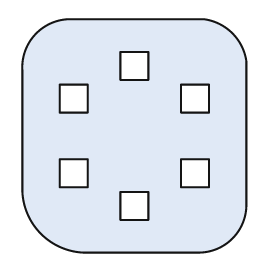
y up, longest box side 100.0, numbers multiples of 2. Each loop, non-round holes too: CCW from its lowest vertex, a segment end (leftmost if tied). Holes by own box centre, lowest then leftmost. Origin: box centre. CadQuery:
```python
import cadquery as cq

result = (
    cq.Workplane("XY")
    .moveTo(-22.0, -50.0)
    .lineTo(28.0, -50.0)
    .threePointArc((42.0, -44.0), (48.0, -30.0))
    .lineTo(48.0, 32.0)
    .threePointArc((42.0, 44.0), (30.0, 50.0))
    .lineTo(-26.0, 50.0)
    .threePointArc((-42.0, 44.0), (-48.0, 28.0))
    .lineTo(-48.0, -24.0)
    .threePointArc((-40.0, -42.0), (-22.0, -50.0))
    .close()
    .moveTo(-6.0, -36.0)
    .lineTo(6.0, -36.0)
    .lineTo(6.0, -24.0)
    .lineTo(-6.0, -24.0)
    .close()
    .moveTo(-32.0, -22.0)
    .lineTo(-20.0, -22.0)
    .lineTo(-20.0, -10.0)
    .lineTo(-32.0, -10.0)
    .close()
    .moveTo(20.0, -22.0)
    .lineTo(32.0, -22.0)
    .lineTo(32.0, -10.0)
    .lineTo(20.0, -10.0)
    .close()
    .moveTo(-32.0, 10.0)
    .lineTo(-20.0, 10.0)
    .lineTo(-20.0, 22.0)
    .lineTo(-32.0, 22.0)
    .close()
    .moveTo(20.0, 10.0)
    .lineTo(32.0, 10.0)
    .lineTo(32.0, 22.0)
    .lineTo(20.0, 22.0)
    .close()
    .moveTo(-6.0, 24.0)
    .lineTo(6.0, 24.0)
    .lineTo(6.0, 36.0)
    .lineTo(-6.0, 36.0)
    .close()
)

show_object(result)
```